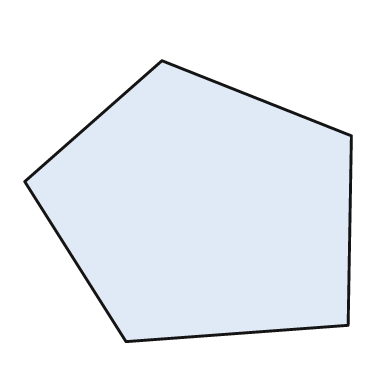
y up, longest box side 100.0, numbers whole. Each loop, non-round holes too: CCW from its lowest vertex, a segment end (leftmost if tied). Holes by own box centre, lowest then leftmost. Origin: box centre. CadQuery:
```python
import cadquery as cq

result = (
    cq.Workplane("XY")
    .moveTo(-19.0, -43.0)
    .lineTo(49.0, -38.0)
    .lineTo(50.0, 20.0)
    .lineTo(-8.0, 43.0)
    .lineTo(-50.0, 6.0)
    .close()
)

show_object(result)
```